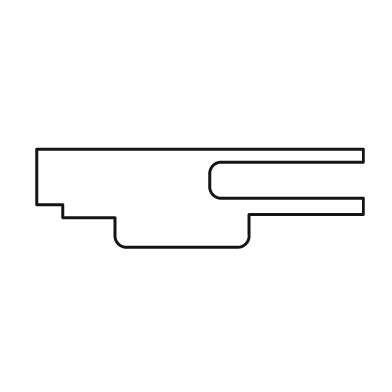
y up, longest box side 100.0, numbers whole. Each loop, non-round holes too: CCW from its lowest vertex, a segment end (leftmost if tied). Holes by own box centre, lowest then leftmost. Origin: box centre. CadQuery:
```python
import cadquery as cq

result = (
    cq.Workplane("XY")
    .moveTo(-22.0, -15.0)
    .lineTo(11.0, -15.0)
    .threePointArc((14.0, -14.0), (15.0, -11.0))
    .lineTo(15.0, -5.0)
    .lineTo(50.0, -5.0)
    .lineTo(50.0, 0.0)
    .lineTo(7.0, 0.0)
    .threePointArc((4.0, 1.0), (3.0, 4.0))
    .lineTo(3.0, 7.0)
    .threePointArc((4.0, 10.0), (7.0, 11.0))
    .lineTo(50.0, 11.0)
    .lineTo(50.0, 15.0)
    .lineTo(-50.0, 15.0)
    .lineTo(-50.0, -2.0)
    .lineTo(-42.0, -2.0)
    .lineTo(-42.0, -6.0)
    .lineTo(-26.0, -6.0)
    .lineTo(-26.0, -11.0)
    .threePointArc((-25.0, -14.0), (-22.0, -15.0))
    .close()
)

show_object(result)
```